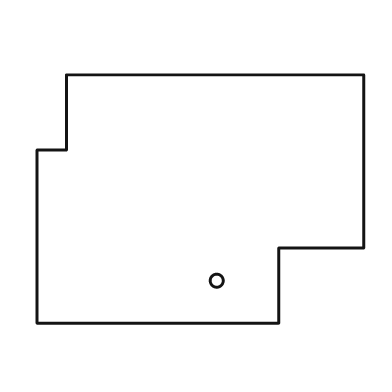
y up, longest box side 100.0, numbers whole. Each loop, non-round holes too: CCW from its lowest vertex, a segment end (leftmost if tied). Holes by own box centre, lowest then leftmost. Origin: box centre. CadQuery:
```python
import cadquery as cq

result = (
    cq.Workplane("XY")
    .moveTo(-50.0, -38.0)
    .lineTo(24.0, -38.0)
    .lineTo(24.0, -15.0)
    .lineTo(50.0, -15.0)
    .lineTo(50.0, 38.0)
    .lineTo(-41.0, 38.0)
    .lineTo(-41.0, 15.0)
    .lineTo(-50.0, 15.0)
    .close()
    .moveTo(5.0, -25.0)
    .circle(2.0)
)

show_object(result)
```